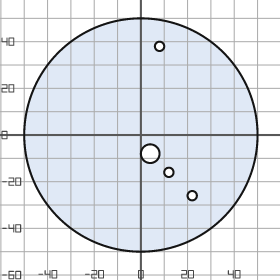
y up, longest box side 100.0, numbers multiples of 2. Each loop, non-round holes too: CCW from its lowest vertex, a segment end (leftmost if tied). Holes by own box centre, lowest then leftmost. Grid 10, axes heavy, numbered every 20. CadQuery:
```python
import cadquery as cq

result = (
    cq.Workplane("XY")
    .moveTo(0.0, 0.0)
    .circle(50.0)
    .moveTo(22.0, -26.0)
    .circle(2.0)
    .moveTo(12.0, -16.0)
    .circle(2.0)
    .moveTo(4.0, -8.0)
    .circle(4.0)
    .moveTo(8.0, 38.0)
    .circle(2.0)
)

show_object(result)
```